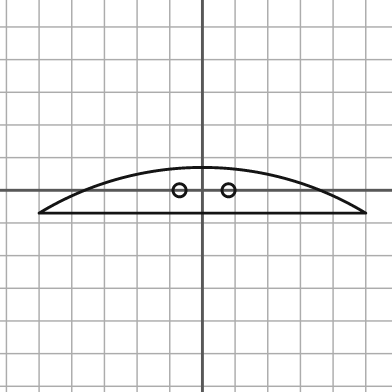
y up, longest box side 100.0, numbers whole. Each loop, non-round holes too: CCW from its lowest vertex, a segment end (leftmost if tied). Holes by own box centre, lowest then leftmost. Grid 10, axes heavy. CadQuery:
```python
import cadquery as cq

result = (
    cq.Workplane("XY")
    .moveTo(-50.0, -7.0)
    .lineTo(50.0, -7.0)
    .threePointArc((0.0, 7.0), (-50.0, -7.0))
    .close()
    .moveTo(-7.0, 0.0)
    .circle(2.0)
    .moveTo(8.0, 0.0)
    .circle(2.0)
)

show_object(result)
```